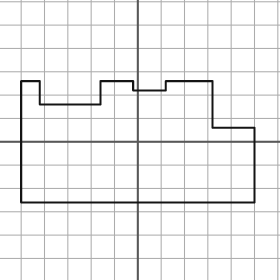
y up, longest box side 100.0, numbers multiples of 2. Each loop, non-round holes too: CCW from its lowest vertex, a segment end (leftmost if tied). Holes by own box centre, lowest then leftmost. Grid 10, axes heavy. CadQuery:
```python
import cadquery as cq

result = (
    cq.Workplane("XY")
    .moveTo(-50.0, -26.0)
    .lineTo(50.0, -26.0)
    .lineTo(50.0, 6.0)
    .lineTo(32.0, 6.0)
    .lineTo(32.0, 26.0)
    .lineTo(12.0, 26.0)
    .lineTo(12.0, 22.0)
    .lineTo(-2.0, 22.0)
    .lineTo(-2.0, 26.0)
    .lineTo(-16.0, 26.0)
    .lineTo(-16.0, 16.0)
    .lineTo(-42.0, 16.0)
    .lineTo(-42.0, 26.0)
    .lineTo(-50.0, 26.0)
    .close()
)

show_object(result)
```